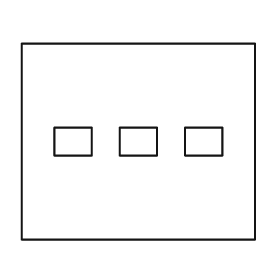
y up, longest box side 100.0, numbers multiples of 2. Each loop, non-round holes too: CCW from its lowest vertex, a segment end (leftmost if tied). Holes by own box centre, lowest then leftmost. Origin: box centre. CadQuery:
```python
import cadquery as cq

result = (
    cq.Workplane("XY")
    .moveTo(-50.0, -42.0)
    .lineTo(50.0, -42.0)
    .lineTo(50.0, 42.0)
    .lineTo(-50.0, 42.0)
    .close()
    .moveTo(-36.0, -6.0)
    .lineTo(-20.0, -6.0)
    .lineTo(-20.0, 6.0)
    .lineTo(-36.0, 6.0)
    .close()
    .moveTo(-8.0, -6.0)
    .lineTo(8.0, -6.0)
    .lineTo(8.0, 6.0)
    .lineTo(-8.0, 6.0)
    .close()
    .moveTo(20.0, -6.0)
    .lineTo(36.0, -6.0)
    .lineTo(36.0, 6.0)
    .lineTo(20.0, 6.0)
    .close()
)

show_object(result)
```